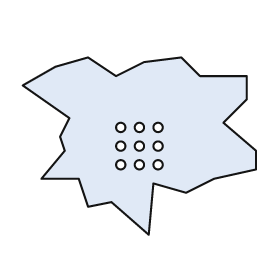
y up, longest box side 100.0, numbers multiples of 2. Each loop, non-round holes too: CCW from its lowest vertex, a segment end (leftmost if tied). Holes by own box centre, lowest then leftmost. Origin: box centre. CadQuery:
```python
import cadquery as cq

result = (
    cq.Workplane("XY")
    .moveTo(4.0, -38.0)
    .lineTo(6.0, -16.0)
    .lineTo(20.0, -20.0)
    .lineTo(32.0, -14.0)
    .lineTo(50.0, -10.0)
    .lineTo(50.0, -2.0)
    .lineTo(36.0, 10.0)
    .lineTo(46.0, 20.0)
    .lineTo(46.0, 30.0)
    .lineTo(26.0, 30.0)
    .lineTo(18.0, 38.0)
    .lineTo(2.0, 36.0)
    .lineTo(-10.0, 30.0)
    .lineTo(-22.0, 38.0)
    .lineTo(-36.0, 34.0)
    .lineTo(-50.0, 26.0)
    .lineTo(-30.0, 12.0)
    .lineTo(-34.0, 4.0)
    .lineTo(-32.0, -2.0)
    .lineTo(-42.0, -14.0)
    .lineTo(-26.0, -14.0)
    .lineTo(-22.0, -26.0)
    .lineTo(-12.0, -24.0)
    .close()
    .moveTo(-8.0, -8.0)
    .circle(2.0)
    .moveTo(0.0, -8.0)
    .circle(2.0)
    .moveTo(8.0, -8.0)
    .circle(2.0)
    .moveTo(-8.0, 0.0)
    .circle(2.0)
    .moveTo(0.0, 0.0)
    .circle(2.0)
    .moveTo(8.0, 0.0)
    .circle(2.0)
    .moveTo(-8.0, 8.0)
    .circle(2.0)
    .moveTo(0.0, 8.0)
    .circle(2.0)
    .moveTo(8.0, 8.0)
    .circle(2.0)
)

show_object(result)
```